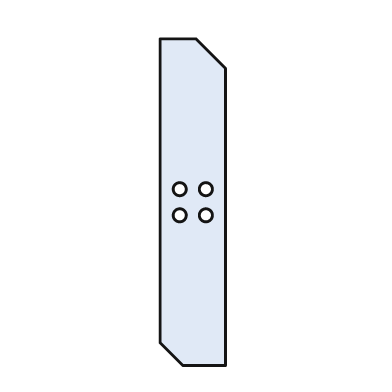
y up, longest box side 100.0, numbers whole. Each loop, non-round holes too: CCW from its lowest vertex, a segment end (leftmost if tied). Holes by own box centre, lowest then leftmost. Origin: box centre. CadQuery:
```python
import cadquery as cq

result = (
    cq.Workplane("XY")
    .moveTo(-3.0, -50.0)
    .lineTo(10.0, -50.0)
    .lineTo(10.0, 41.0)
    .lineTo(1.0, 50.0)
    .lineTo(-10.0, 50.0)
    .lineTo(-10.0, -43.0)
    .close()
    .moveTo(-4.0, -4.0)
    .circle(2.0)
    .moveTo(4.0, -4.0)
    .circle(2.0)
    .moveTo(-4.0, 4.0)
    .circle(2.0)
    .moveTo(4.0, 4.0)
    .circle(2.0)
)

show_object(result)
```